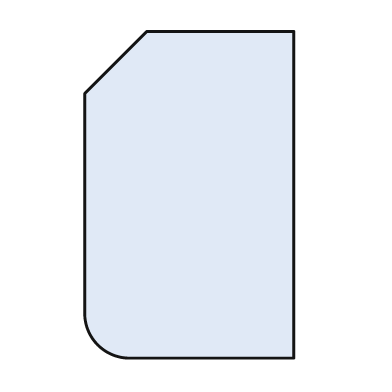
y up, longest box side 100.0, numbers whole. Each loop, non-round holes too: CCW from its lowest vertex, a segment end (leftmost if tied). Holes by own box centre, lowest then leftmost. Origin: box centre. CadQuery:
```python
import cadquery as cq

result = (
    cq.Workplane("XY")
    .moveTo(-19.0, -50.0)
    .lineTo(32.0, -50.0)
    .lineTo(32.0, 50.0)
    .lineTo(-13.0, 50.0)
    .lineTo(-32.0, 31.0)
    .lineTo(-32.0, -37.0)
    .threePointArc((-28.0, -46.0), (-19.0, -50.0))
    .close()
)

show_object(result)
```